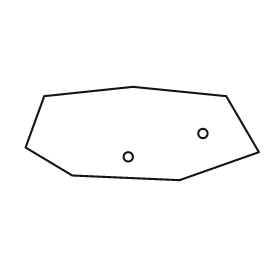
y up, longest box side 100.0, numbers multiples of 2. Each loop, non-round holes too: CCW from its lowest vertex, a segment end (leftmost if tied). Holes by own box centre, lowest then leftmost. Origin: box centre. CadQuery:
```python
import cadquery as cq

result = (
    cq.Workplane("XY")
    .moveTo(16.0, -20.0)
    .lineTo(50.0, -8.0)
    .lineTo(36.0, 16.0)
    .lineTo(-4.0, 20.0)
    .lineTo(-42.0, 16.0)
    .lineTo(-50.0, -6.0)
    .lineTo(-30.0, -18.0)
    .close()
    .moveTo(-6.0, -10.0)
    .circle(2.0)
    .moveTo(26.0, 0.0)
    .circle(2.0)
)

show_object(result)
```